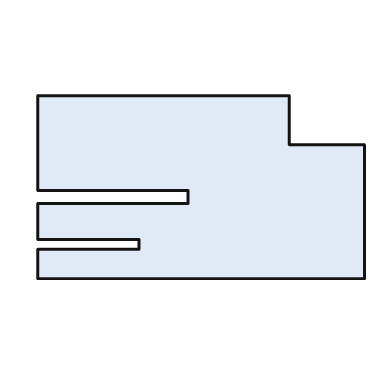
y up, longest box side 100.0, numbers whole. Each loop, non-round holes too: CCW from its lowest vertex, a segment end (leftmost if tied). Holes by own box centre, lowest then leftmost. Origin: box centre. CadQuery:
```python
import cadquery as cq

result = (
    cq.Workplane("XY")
    .moveTo(-50.0, -28.0)
    .lineTo(50.0, -28.0)
    .lineTo(50.0, 13.0)
    .lineTo(27.0, 13.0)
    .lineTo(27.0, 28.0)
    .lineTo(-50.0, 28.0)
    .lineTo(-50.0, -1.0)
    .lineTo(-4.0, -1.0)
    .lineTo(-4.0, -5.0)
    .lineTo(-50.0, -5.0)
    .lineTo(-50.0, -16.0)
    .lineTo(-19.0, -16.0)
    .lineTo(-19.0, -19.0)
    .lineTo(-50.0, -19.0)
    .close()
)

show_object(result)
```